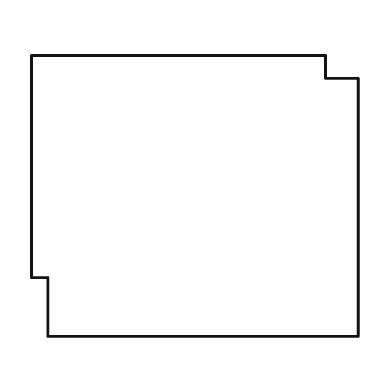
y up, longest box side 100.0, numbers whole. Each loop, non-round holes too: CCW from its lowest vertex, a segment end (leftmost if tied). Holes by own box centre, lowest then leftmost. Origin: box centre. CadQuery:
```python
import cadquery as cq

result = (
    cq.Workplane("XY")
    .moveTo(-45.0, -43.0)
    .lineTo(50.0, -43.0)
    .lineTo(50.0, 36.0)
    .lineTo(40.0, 36.0)
    .lineTo(40.0, 43.0)
    .lineTo(-50.0, 43.0)
    .lineTo(-50.0, -25.0)
    .lineTo(-45.0, -25.0)
    .close()
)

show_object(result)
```